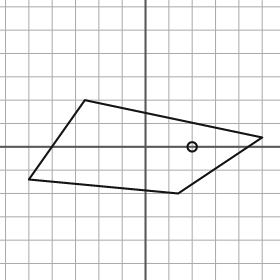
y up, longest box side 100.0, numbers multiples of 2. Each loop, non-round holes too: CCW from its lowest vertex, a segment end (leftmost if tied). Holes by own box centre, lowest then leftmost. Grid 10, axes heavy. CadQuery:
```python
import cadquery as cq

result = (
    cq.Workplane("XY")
    .moveTo(14.0, -20.0)
    .lineTo(50.0, 4.0)
    .lineTo(-26.0, 20.0)
    .lineTo(-50.0, -14.0)
    .close()
    .moveTo(20.0, 0.0)
    .circle(2.0)
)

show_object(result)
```